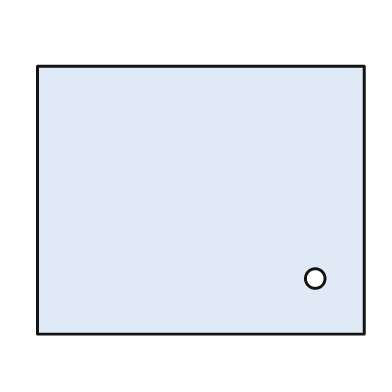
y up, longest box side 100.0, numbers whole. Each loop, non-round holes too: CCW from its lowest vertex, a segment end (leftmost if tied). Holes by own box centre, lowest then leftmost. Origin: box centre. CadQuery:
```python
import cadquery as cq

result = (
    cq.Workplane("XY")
    .moveTo(-50.0, -41.0)
    .lineTo(50.0, -41.0)
    .lineTo(50.0, 41.0)
    .lineTo(-50.0, 41.0)
    .close()
    .moveTo(35.0, -24.0)
    .circle(3.0)
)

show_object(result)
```